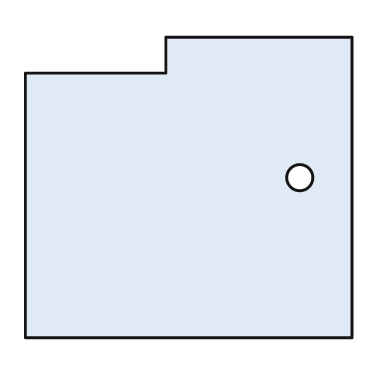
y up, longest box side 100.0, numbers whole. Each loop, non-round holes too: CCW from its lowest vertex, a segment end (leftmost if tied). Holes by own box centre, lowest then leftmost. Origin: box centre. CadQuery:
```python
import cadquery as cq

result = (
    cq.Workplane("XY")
    .moveTo(-50.0, -46.0)
    .lineTo(50.0, -46.0)
    .lineTo(50.0, 46.0)
    .lineTo(-7.0, 46.0)
    .lineTo(-7.0, 35.0)
    .lineTo(-50.0, 35.0)
    .close()
    .moveTo(34.0, 3.0)
    .circle(4.0)
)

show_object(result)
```